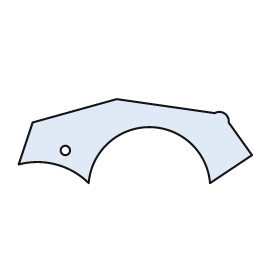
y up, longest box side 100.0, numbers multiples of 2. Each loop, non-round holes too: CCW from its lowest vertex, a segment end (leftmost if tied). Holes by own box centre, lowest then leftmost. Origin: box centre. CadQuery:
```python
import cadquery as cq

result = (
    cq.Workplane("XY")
    .moveTo(-20.0, -18.0)
    .threePointArc((6.0, 6.0), (32.0, -18.0))
    .lineTo(50.0, -6.0)
    .lineTo(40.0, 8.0)
    .threePointArc((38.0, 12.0), (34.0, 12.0))
    .lineTo(-8.0, 18.0)
    .lineTo(-44.0, 8.0)
    .lineTo(-50.0, -10.0)
    .threePointArc((-34.0, -10.0), (-20.0, -18.0))
    .close()
    .moveTo(-30.0, -4.0)
    .circle(2.0)
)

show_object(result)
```